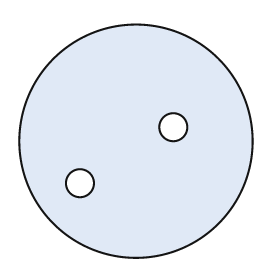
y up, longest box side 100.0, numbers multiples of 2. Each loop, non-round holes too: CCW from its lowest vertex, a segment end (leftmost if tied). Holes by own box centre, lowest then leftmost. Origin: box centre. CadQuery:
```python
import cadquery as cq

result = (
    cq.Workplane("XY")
    .moveTo(0.0, 0.0)
    .circle(50.0)
    .moveTo(-24.0, -18.0)
    .circle(6.0)
    .moveTo(16.0, 6.0)
    .circle(6.0)
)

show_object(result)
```